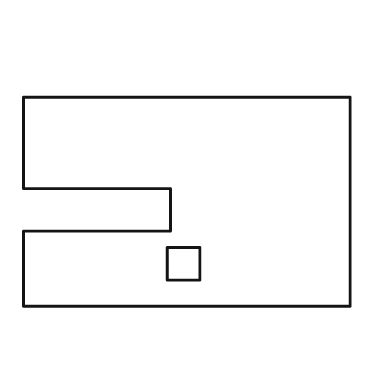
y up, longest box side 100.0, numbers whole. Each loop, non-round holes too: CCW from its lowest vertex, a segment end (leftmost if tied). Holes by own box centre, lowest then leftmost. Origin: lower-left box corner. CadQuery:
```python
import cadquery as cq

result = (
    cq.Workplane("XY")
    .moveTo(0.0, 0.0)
    .lineTo(100.0, 0.0)
    .lineTo(100.0, 64.0)
    .lineTo(0.0, 64.0)
    .lineTo(0.0, 36.0)
    .lineTo(45.0, 36.0)
    .lineTo(45.0, 23.0)
    .lineTo(0.0, 23.0)
    .close()
    .moveTo(44.0, 8.0)
    .lineTo(54.0, 8.0)
    .lineTo(54.0, 18.0)
    .lineTo(44.0, 18.0)
    .close()
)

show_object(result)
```